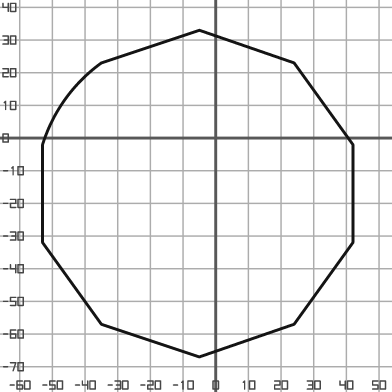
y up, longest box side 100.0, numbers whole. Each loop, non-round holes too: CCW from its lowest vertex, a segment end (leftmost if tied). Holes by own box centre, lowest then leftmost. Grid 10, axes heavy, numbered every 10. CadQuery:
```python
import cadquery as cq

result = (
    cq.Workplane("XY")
    .moveTo(-5.0, -67.0)
    .lineTo(24.0, -57.0)
    .lineTo(42.0, -32.0)
    .lineTo(42.0, -2.0)
    .lineTo(24.0, 23.0)
    .lineTo(-5.0, 33.0)
    .lineTo(-35.0, 23.0)
    .threePointArc((-46.0, 12.0), (-53.0, -2.0))
    .lineTo(-53.0, -32.0)
    .lineTo(-35.0, -57.0)
    .close()
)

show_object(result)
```